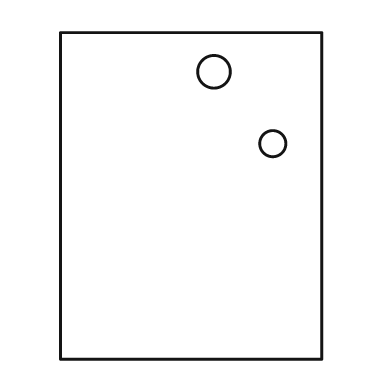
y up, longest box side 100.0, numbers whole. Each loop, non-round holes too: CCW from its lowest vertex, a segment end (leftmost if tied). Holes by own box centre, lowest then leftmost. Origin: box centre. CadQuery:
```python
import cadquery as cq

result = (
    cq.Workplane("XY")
    .moveTo(-40.0, -50.0)
    .lineTo(40.0, -50.0)
    .lineTo(40.0, 50.0)
    .lineTo(-40.0, 50.0)
    .close()
    .moveTo(25.0, 16.0)
    .circle(4.0)
    .moveTo(7.0, 38.0)
    .circle(5.0)
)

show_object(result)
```